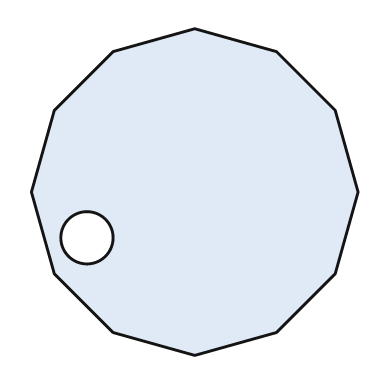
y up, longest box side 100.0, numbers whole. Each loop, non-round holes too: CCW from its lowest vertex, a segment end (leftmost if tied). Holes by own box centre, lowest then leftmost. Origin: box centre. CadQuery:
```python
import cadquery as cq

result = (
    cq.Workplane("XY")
    .moveTo(0.0, -50.0)
    .lineTo(25.0, -43.0)
    .lineTo(43.0, -25.0)
    .lineTo(50.0, 0.0)
    .lineTo(43.0, 25.0)
    .lineTo(25.0, 43.0)
    .lineTo(0.0, 50.0)
    .lineTo(-25.0, 43.0)
    .lineTo(-43.0, 25.0)
    .lineTo(-50.0, 0.0)
    .lineTo(-43.0, -25.0)
    .lineTo(-25.0, -43.0)
    .close()
    .moveTo(-33.0, -14.0)
    .circle(8.0)
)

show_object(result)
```